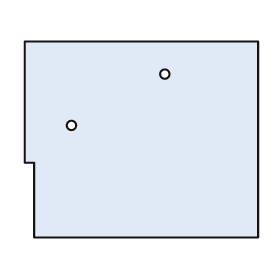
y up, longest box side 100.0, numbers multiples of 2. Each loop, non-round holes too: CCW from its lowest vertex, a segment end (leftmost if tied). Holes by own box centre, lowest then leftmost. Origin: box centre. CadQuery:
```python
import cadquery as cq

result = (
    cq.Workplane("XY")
    .moveTo(-46.0, -42.0)
    .lineTo(50.0, -42.0)
    .lineTo(50.0, 42.0)
    .lineTo(-50.0, 42.0)
    .lineTo(-50.0, -10.0)
    .lineTo(-46.0, -10.0)
    .close()
    .moveTo(-30.0, 6.0)
    .circle(2.0)
    .moveTo(10.0, 28.0)
    .circle(2.0)
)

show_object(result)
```